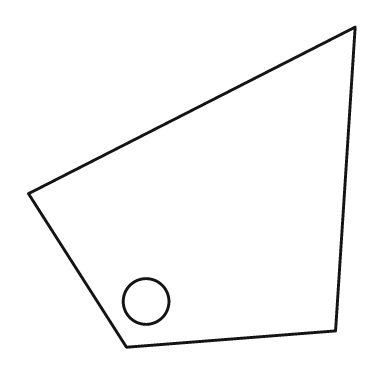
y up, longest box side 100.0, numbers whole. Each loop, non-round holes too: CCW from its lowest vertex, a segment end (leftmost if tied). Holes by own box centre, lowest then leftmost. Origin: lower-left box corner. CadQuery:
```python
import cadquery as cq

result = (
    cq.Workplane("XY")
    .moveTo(30.0, 0.0)
    .lineTo(94.0, 5.0)
    .lineTo(100.0, 98.0)
    .lineTo(0.0, 47.0)
    .close()
    .moveTo(36.0, 14.0)
    .circle(7.0)
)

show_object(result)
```